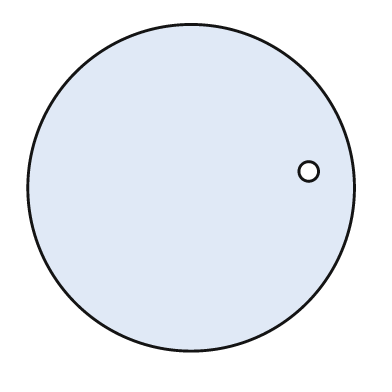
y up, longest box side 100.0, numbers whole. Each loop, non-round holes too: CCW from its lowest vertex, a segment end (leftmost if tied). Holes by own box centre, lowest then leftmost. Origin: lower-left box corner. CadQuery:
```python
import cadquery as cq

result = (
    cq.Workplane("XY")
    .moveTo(50.0, 50.0)
    .circle(50.0)
    .moveTo(86.0, 55.0)
    .circle(3.0)
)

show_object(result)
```